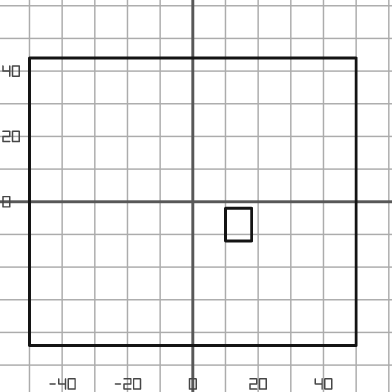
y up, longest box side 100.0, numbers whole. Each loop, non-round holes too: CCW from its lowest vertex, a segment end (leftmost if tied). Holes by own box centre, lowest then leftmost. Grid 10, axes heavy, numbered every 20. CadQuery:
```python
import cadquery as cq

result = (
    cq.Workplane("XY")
    .moveTo(-50.0, -44.0)
    .lineTo(50.0, -44.0)
    .lineTo(50.0, 44.0)
    .lineTo(-50.0, 44.0)
    .close()
    .moveTo(10.0, -12.0)
    .lineTo(18.0, -12.0)
    .lineTo(18.0, -2.0)
    .lineTo(10.0, -2.0)
    .close()
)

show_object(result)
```